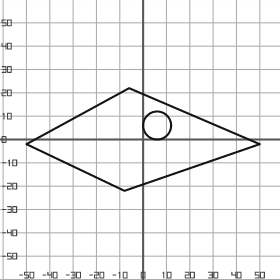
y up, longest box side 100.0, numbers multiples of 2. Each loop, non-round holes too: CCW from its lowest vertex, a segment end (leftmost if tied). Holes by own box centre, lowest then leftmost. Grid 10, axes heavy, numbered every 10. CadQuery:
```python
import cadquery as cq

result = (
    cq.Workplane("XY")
    .moveTo(-8.0, -22.0)
    .lineTo(50.0, -2.0)
    .lineTo(-6.0, 22.0)
    .lineTo(-50.0, -2.0)
    .close()
    .moveTo(6.0, 6.0)
    .circle(6.0)
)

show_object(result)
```